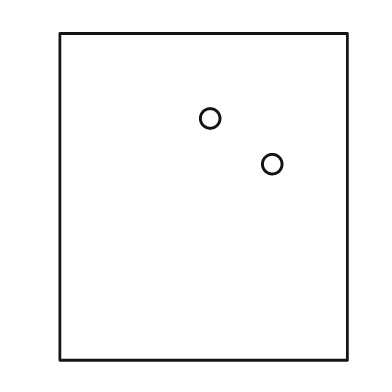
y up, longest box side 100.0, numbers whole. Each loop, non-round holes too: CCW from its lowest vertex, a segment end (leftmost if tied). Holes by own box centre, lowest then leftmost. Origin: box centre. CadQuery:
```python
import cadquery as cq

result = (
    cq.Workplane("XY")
    .moveTo(-44.0, -50.0)
    .lineTo(44.0, -50.0)
    .lineTo(44.0, 50.0)
    .lineTo(-44.0, 50.0)
    .close()
    .moveTo(21.0, 10.0)
    .circle(3.0)
    .moveTo(2.0, 24.0)
    .circle(3.0)
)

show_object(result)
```